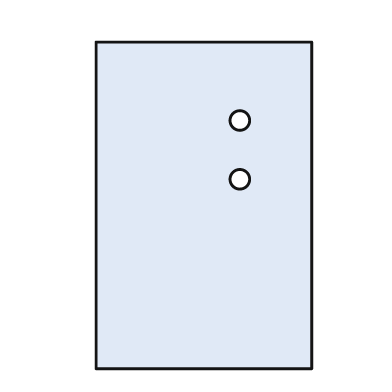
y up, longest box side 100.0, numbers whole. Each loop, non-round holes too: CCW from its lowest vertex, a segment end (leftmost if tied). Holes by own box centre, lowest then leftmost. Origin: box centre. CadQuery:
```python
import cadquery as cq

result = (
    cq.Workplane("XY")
    .moveTo(-33.0, -50.0)
    .lineTo(33.0, -50.0)
    .lineTo(33.0, 50.0)
    .lineTo(-33.0, 50.0)
    .close()
    .moveTo(11.0, 8.0)
    .circle(3.0)
    .moveTo(11.0, 26.0)
    .circle(3.0)
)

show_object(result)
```